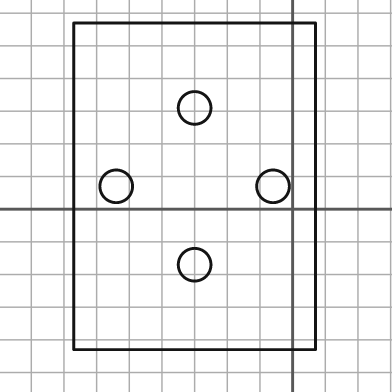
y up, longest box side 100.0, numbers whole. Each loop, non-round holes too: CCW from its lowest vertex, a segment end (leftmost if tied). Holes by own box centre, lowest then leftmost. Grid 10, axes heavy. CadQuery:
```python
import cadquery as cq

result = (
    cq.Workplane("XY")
    .moveTo(-67.0, -43.0)
    .lineTo(7.0, -43.0)
    .lineTo(7.0, 57.0)
    .lineTo(-67.0, 57.0)
    .close()
    .moveTo(-30.0, -17.0)
    .circle(5.0)
    .moveTo(-54.0, 7.0)
    .circle(5.0)
    .moveTo(-6.0, 7.0)
    .circle(5.0)
    .moveTo(-30.0, 31.0)
    .circle(5.0)
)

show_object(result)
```